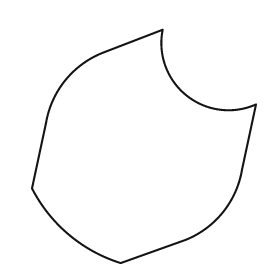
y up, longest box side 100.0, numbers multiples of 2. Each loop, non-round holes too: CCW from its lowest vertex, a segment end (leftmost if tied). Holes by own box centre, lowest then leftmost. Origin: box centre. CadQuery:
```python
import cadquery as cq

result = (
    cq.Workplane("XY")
    .moveTo(-10.0, -50.0)
    .lineTo(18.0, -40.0)
    .threePointArc((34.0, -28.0), (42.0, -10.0))
    .lineTo(48.0, 18.0)
    .threePointArc((18.0, 22.0), (8.0, 50.0))
    .lineTo(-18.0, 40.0)
    .threePointArc((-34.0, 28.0), (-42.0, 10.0))
    .lineTo(-48.0, -18.0)
    .threePointArc((-32.0, -38.0), (-10.0, -50.0))
    .close()
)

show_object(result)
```